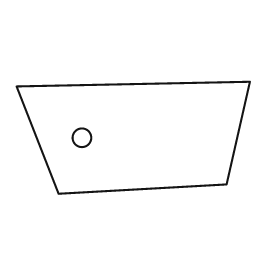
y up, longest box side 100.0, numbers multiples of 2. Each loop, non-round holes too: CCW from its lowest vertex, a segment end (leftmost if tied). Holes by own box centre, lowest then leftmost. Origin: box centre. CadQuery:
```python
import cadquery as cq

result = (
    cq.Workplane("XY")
    .moveTo(-32.0, -24.0)
    .lineTo(40.0, -20.0)
    .lineTo(50.0, 24.0)
    .lineTo(-50.0, 22.0)
    .close()
    .moveTo(-22.0, 0.0)
    .circle(4.0)
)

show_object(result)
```